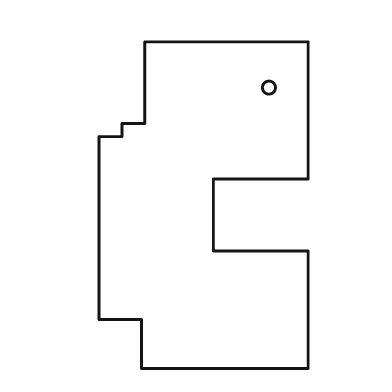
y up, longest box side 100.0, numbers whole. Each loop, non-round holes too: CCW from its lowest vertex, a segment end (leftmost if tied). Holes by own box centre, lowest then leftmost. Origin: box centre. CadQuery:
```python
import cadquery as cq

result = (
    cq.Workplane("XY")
    .moveTo(-19.0, -50.0)
    .lineTo(32.0, -50.0)
    .lineTo(32.0, -14.0)
    .lineTo(3.0, -14.0)
    .lineTo(3.0, 8.0)
    .lineTo(32.0, 8.0)
    .lineTo(32.0, 50.0)
    .lineTo(-18.0, 50.0)
    .lineTo(-18.0, 25.0)
    .lineTo(-25.0, 25.0)
    .lineTo(-25.0, 21.0)
    .lineTo(-32.0, 21.0)
    .lineTo(-32.0, -35.0)
    .lineTo(-19.0, -35.0)
    .close()
    .moveTo(20.0, 36.0)
    .circle(2.0)
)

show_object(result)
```